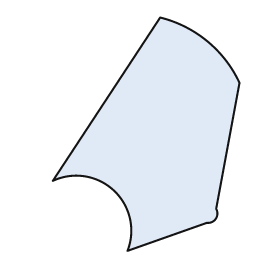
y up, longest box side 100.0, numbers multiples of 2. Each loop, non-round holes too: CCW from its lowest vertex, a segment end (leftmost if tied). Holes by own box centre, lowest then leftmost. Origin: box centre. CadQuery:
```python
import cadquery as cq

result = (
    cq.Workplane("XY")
    .moveTo(-8.0, -50.0)
    .lineTo(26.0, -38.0)
    .threePointArc((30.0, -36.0), (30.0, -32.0))
    .lineTo(40.0, 22.0)
    .threePointArc((26.0, 40.0), (6.0, 50.0))
    .lineTo(-40.0, -20.0)
    .threePointArc((-14.0, -24.0), (-8.0, -50.0))
    .close()
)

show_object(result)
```